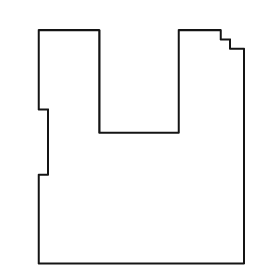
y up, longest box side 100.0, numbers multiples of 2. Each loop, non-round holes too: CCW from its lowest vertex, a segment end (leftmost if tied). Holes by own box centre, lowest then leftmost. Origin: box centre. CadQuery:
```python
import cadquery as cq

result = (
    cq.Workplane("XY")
    .moveTo(-44.0, -50.0)
    .lineTo(44.0, -50.0)
    .lineTo(44.0, 42.0)
    .lineTo(38.0, 42.0)
    .lineTo(38.0, 46.0)
    .lineTo(34.0, 46.0)
    .lineTo(34.0, 50.0)
    .lineTo(16.0, 50.0)
    .lineTo(16.0, 6.0)
    .lineTo(-18.0, 6.0)
    .lineTo(-18.0, 50.0)
    .lineTo(-44.0, 50.0)
    .lineTo(-44.0, 16.0)
    .lineTo(-40.0, 16.0)
    .lineTo(-40.0, -12.0)
    .lineTo(-44.0, -12.0)
    .close()
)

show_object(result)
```